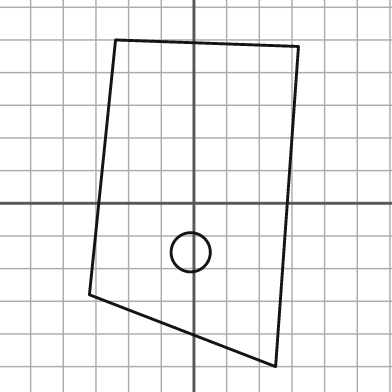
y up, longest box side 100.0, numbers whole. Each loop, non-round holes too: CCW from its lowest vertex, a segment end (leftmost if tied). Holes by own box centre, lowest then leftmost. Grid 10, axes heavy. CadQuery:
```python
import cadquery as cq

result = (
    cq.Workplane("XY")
    .moveTo(25.0, -50.0)
    .lineTo(32.0, 48.0)
    .lineTo(-24.0, 50.0)
    .lineTo(-32.0, -28.0)
    .close()
    .moveTo(-1.0, -15.0)
    .circle(6.0)
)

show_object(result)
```